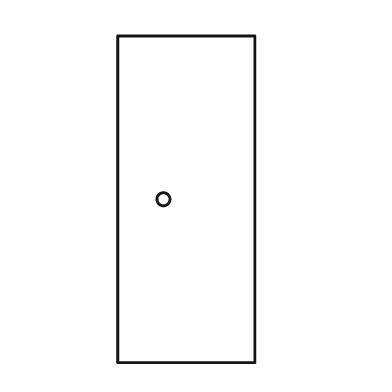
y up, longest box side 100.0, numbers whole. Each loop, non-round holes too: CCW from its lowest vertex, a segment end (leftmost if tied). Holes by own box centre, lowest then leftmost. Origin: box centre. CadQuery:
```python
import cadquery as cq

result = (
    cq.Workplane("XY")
    .moveTo(-21.0, -50.0)
    .lineTo(21.0, -50.0)
    .lineTo(21.0, 50.0)
    .lineTo(-21.0, 50.0)
    .close()
    .moveTo(-7.0, 0.0)
    .circle(2.0)
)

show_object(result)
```